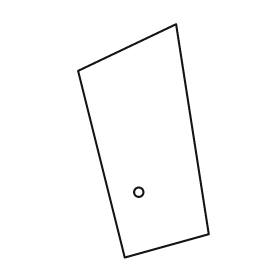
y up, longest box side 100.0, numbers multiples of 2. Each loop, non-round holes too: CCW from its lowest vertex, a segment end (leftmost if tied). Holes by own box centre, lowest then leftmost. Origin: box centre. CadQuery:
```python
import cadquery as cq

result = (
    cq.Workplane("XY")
    .moveTo(-8.0, -50.0)
    .lineTo(28.0, -40.0)
    .lineTo(14.0, 50.0)
    .lineTo(-28.0, 30.0)
    .close()
    .moveTo(-2.0, -22.0)
    .circle(2.0)
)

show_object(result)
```